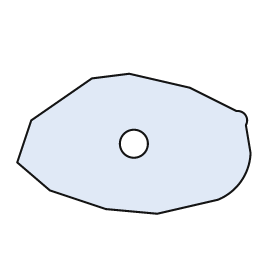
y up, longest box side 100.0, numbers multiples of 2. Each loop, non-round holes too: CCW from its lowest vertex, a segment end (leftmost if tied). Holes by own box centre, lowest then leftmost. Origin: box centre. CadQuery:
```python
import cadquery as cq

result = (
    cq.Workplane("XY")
    .moveTo(10.0, -30.0)
    .lineTo(36.0, -24.0)
    .threePointArc((46.0, -16.0), (50.0, -4.0))
    .lineTo(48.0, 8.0)
    .threePointArc((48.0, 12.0), (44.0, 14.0))
    .lineTo(24.0, 24.0)
    .lineTo(-2.0, 30.0)
    .lineTo(-18.0, 28.0)
    .lineTo(-44.0, 10.0)
    .lineTo(-50.0, -8.0)
    .lineTo(-36.0, -20.0)
    .lineTo(-12.0, -28.0)
    .close()
    .moveTo(0.0, 0.0)
    .circle(6.0)
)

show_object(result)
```